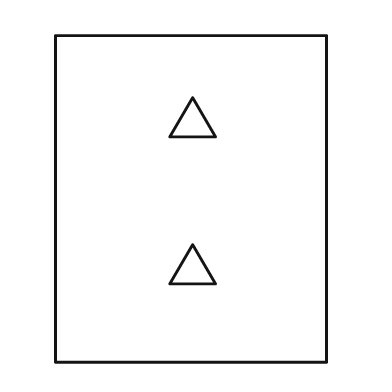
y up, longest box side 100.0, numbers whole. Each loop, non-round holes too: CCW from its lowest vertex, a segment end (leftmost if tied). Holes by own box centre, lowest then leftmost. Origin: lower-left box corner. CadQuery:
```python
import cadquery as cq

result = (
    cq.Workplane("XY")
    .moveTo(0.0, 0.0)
    .lineTo(83.0, 0.0)
    .lineTo(83.0, 100.0)
    .lineTo(0.0, 100.0)
    .close()
    .moveTo(35.0, 24.0)
    .lineTo(49.0, 24.0)
    .lineTo(42.0, 36.0)
    .close()
    .moveTo(35.0, 69.0)
    .lineTo(49.0, 69.0)
    .lineTo(42.0, 81.0)
    .close()
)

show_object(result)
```